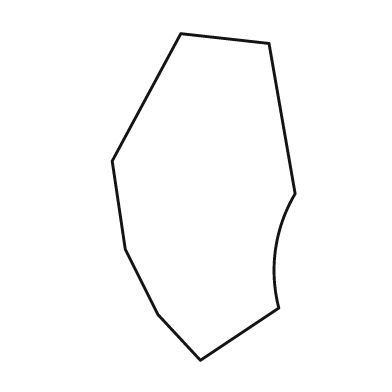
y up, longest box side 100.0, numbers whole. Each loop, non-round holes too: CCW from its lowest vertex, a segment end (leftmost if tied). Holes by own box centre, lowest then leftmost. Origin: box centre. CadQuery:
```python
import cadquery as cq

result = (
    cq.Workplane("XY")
    .moveTo(-1.0, -50.0)
    .lineTo(23.0, -34.0)
    .threePointArc((22.0, -16.0), (28.0, 1.0))
    .lineTo(20.0, 47.0)
    .lineTo(-7.0, 50.0)
    .lineTo(-28.0, 11.0)
    .lineTo(-24.0, -16.0)
    .lineTo(-14.0, -36.0)
    .close()
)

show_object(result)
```